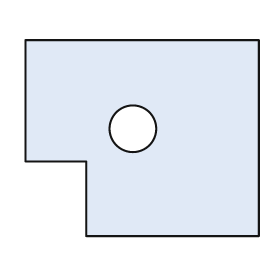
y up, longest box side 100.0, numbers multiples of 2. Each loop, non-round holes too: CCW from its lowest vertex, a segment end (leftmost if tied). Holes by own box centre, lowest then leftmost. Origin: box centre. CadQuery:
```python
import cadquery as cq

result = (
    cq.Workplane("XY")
    .moveTo(-24.0, -42.0)
    .lineTo(50.0, -42.0)
    .lineTo(50.0, 42.0)
    .lineTo(-50.0, 42.0)
    .lineTo(-50.0, -10.0)
    .lineTo(-24.0, -10.0)
    .close()
    .moveTo(-4.0, 4.0)
    .circle(10.0)
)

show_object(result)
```